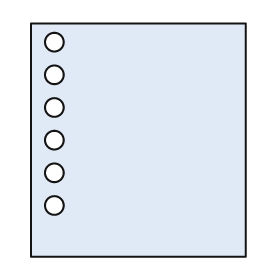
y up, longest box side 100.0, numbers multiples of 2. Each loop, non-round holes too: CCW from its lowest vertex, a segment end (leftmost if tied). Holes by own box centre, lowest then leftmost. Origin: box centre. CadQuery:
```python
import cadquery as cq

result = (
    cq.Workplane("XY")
    .moveTo(-46.0, -50.0)
    .lineTo(46.0, -50.0)
    .lineTo(46.0, 50.0)
    .lineTo(-46.0, 50.0)
    .close()
    .moveTo(-36.0, -28.0)
    .circle(4.0)
    .moveTo(-36.0, -14.0)
    .circle(4.0)
    .moveTo(-36.0, 0.0)
    .circle(4.0)
    .moveTo(-36.0, 14.0)
    .circle(4.0)
    .moveTo(-36.0, 28.0)
    .circle(4.0)
    .moveTo(-36.0, 42.0)
    .circle(4.0)
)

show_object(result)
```